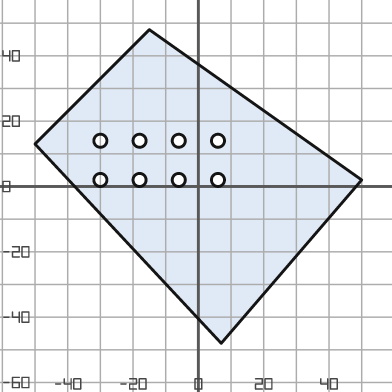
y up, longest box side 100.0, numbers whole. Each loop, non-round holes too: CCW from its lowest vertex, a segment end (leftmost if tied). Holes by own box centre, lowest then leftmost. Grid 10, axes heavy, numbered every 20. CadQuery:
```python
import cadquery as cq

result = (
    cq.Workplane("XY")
    .moveTo(7.0, -48.0)
    .lineTo(50.0, 2.0)
    .lineTo(-15.0, 48.0)
    .lineTo(-50.0, 13.0)
    .close()
    .moveTo(-30.0, 2.0)
    .circle(2.0)
    .moveTo(-18.0, 2.0)
    .circle(2.0)
    .moveTo(-6.0, 2.0)
    .circle(2.0)
    .moveTo(6.0, 2.0)
    .circle(2.0)
    .moveTo(-30.0, 14.0)
    .circle(2.0)
    .moveTo(-18.0, 14.0)
    .circle(2.0)
    .moveTo(-6.0, 14.0)
    .circle(2.0)
    .moveTo(6.0, 14.0)
    .circle(2.0)
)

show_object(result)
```